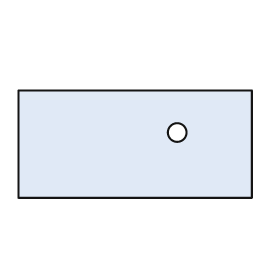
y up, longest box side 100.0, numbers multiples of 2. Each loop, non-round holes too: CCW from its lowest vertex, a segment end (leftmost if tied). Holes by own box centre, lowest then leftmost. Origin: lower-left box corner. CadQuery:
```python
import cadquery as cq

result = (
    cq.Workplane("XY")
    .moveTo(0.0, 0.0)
    .lineTo(100.0, 0.0)
    .lineTo(100.0, 46.0)
    .lineTo(0.0, 46.0)
    .close()
    .moveTo(68.0, 28.0)
    .circle(4.0)
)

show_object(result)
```